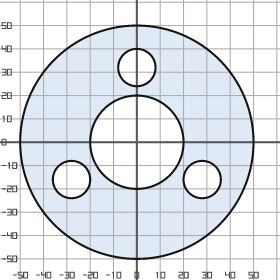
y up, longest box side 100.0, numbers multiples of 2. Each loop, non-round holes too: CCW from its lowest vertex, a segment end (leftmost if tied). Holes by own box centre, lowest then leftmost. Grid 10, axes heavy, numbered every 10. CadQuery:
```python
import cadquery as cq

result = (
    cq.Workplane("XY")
    .moveTo(0.0, 0.0)
    .circle(50.0)
    .moveTo(-28.0, -16.0)
    .circle(8.0)
    .moveTo(28.0, -16.0)
    .circle(8.0)
    .moveTo(0.0, 0.0)
    .circle(20.0)
    .moveTo(0.0, 32.0)
    .circle(8.0)
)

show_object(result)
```